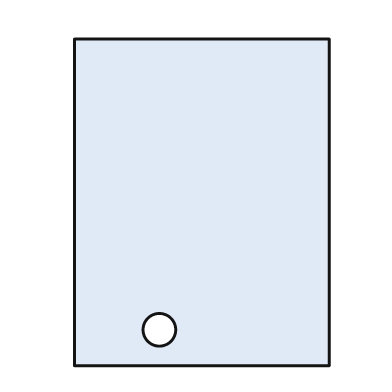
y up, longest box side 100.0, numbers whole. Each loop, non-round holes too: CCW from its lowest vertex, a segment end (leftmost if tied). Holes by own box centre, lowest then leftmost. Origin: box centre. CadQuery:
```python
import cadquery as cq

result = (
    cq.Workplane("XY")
    .moveTo(-39.0, -50.0)
    .lineTo(39.0, -50.0)
    .lineTo(39.0, 50.0)
    .lineTo(-39.0, 50.0)
    .close()
    .moveTo(-13.0, -39.0)
    .circle(5.0)
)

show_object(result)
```